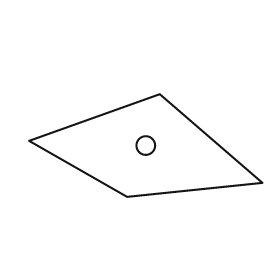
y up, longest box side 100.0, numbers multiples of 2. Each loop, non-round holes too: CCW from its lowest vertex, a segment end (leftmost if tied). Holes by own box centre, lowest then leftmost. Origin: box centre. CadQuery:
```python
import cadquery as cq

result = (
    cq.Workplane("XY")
    .moveTo(-8.0, -22.0)
    .lineTo(50.0, -16.0)
    .lineTo(6.0, 22.0)
    .lineTo(-50.0, 2.0)
    .close()
    .moveTo(0.0, 0.0)
    .circle(4.0)
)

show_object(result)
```